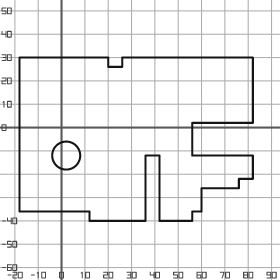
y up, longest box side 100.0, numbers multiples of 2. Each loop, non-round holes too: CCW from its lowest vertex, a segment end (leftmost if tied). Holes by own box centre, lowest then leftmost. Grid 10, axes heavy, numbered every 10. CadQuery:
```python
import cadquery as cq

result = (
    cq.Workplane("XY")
    .moveTo(12.0, -40.0)
    .lineTo(36.0, -40.0)
    .lineTo(36.0, -12.0)
    .lineTo(42.0, -12.0)
    .lineTo(42.0, -40.0)
    .lineTo(56.0, -40.0)
    .lineTo(56.0, -36.0)
    .lineTo(60.0, -36.0)
    .lineTo(60.0, -26.0)
    .lineTo(76.0, -26.0)
    .lineTo(76.0, -22.0)
    .lineTo(82.0, -22.0)
    .lineTo(82.0, -12.0)
    .lineTo(56.0, -12.0)
    .lineTo(56.0, 2.0)
    .lineTo(82.0, 2.0)
    .lineTo(82.0, 30.0)
    .lineTo(26.0, 30.0)
    .lineTo(26.0, 26.0)
    .lineTo(20.0, 26.0)
    .lineTo(20.0, 30.0)
    .lineTo(-18.0, 30.0)
    .lineTo(-18.0, -36.0)
    .lineTo(12.0, -36.0)
    .close()
    .moveTo(2.0, -12.0)
    .circle(6.0)
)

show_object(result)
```